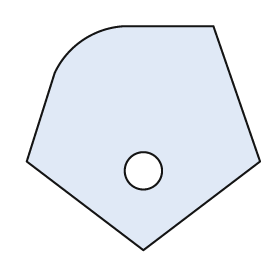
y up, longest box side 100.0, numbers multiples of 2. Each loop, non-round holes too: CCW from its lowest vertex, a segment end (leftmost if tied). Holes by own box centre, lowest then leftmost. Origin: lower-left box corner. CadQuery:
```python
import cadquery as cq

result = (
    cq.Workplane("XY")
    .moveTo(50.0, 0.0)
    .lineTo(100.0, 38.0)
    .lineTo(80.0, 96.0)
    .lineTo(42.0, 96.0)
    .threePointArc((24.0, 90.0), (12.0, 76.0))
    .lineTo(0.0, 38.0)
    .close()
    .moveTo(50.0, 34.0)
    .circle(8.0)
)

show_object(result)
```